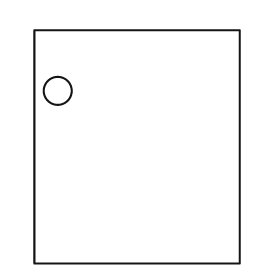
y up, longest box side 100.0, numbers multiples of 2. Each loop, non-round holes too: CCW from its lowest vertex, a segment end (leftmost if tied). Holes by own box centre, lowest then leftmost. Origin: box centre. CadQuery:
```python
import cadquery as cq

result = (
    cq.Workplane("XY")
    .moveTo(-44.0, -50.0)
    .lineTo(44.0, -50.0)
    .lineTo(44.0, 50.0)
    .lineTo(-44.0, 50.0)
    .close()
    .moveTo(-34.0, 24.0)
    .circle(6.0)
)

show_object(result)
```